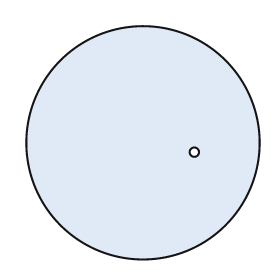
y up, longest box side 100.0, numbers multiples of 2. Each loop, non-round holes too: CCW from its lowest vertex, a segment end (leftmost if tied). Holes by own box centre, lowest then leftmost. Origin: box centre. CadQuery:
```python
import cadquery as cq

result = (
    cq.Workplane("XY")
    .moveTo(0.0, 0.0)
    .circle(50.0)
    .moveTo(22.0, -4.0)
    .circle(2.0)
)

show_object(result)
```